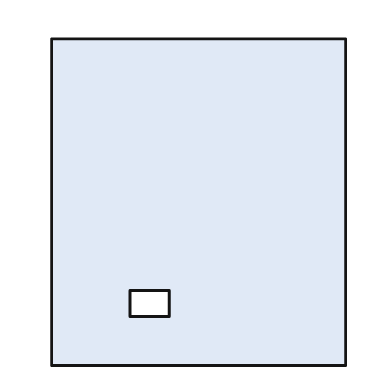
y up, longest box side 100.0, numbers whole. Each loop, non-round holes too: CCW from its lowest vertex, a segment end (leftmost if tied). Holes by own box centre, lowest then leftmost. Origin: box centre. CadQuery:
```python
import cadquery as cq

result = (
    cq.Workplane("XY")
    .moveTo(-45.0, -50.0)
    .lineTo(45.0, -50.0)
    .lineTo(45.0, 50.0)
    .lineTo(-45.0, 50.0)
    .close()
    .moveTo(-21.0, -35.0)
    .lineTo(-9.0, -35.0)
    .lineTo(-9.0, -27.0)
    .lineTo(-21.0, -27.0)
    .close()
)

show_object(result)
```